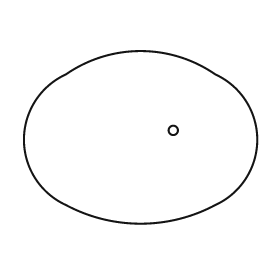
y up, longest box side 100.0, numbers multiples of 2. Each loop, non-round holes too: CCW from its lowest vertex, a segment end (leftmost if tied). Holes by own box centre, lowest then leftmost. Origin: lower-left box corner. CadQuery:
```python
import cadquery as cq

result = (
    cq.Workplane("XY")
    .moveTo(18.0, 8.0)
    .threePointArc((50.0, 0.0), (82.0, 8.0))
    .threePointArc((100.0, 36.0), (82.0, 64.0))
    .threePointArc((50.0, 74.0), (18.0, 64.0))
    .threePointArc((0.0, 36.0), (18.0, 8.0))
    .close()
    .moveTo(64.0, 40.0)
    .circle(2.0)
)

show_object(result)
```